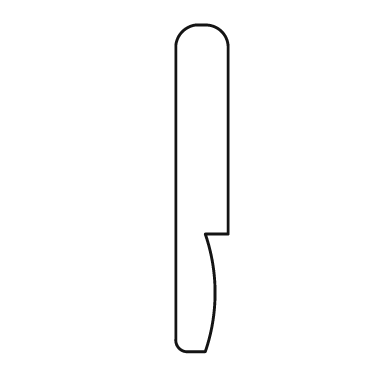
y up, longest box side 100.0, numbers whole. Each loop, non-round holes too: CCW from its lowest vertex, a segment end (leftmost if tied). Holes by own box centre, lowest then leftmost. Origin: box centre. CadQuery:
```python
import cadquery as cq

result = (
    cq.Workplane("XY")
    .moveTo(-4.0, -50.0)
    .lineTo(1.0, -50.0)
    .threePointArc((4.0, -32.0), (1.0, -14.0))
    .lineTo(8.0, -14.0)
    .lineTo(8.0, 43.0)
    .threePointArc((6.0, 48.0), (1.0, 50.0))
    .lineTo(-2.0, 50.0)
    .threePointArc((-6.0, 48.0), (-8.0, 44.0))
    .lineTo(-8.0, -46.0)
    .threePointArc((-7.0, -49.0), (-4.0, -50.0))
    .close()
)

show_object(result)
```